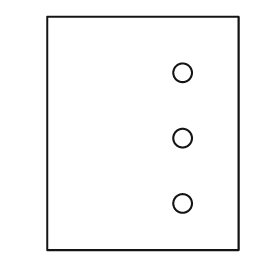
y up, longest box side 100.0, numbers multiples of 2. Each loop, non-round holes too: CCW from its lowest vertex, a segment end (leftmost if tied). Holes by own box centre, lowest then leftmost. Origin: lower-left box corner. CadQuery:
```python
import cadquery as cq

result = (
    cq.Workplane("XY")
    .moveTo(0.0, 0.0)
    .lineTo(82.0, 0.0)
    .lineTo(82.0, 100.0)
    .lineTo(0.0, 100.0)
    .close()
    .moveTo(58.0, 20.0)
    .circle(4.0)
    .moveTo(58.0, 48.0)
    .circle(4.0)
    .moveTo(58.0, 76.0)
    .circle(4.0)
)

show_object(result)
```